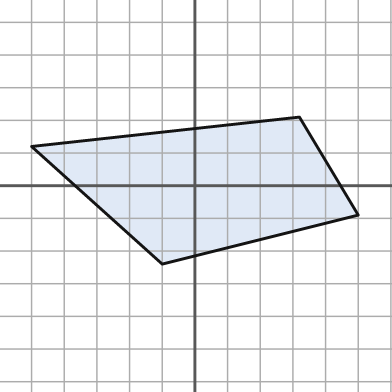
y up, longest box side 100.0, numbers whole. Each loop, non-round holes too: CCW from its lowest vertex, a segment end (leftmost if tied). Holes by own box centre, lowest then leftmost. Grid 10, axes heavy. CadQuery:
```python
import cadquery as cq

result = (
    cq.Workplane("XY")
    .moveTo(-10.0, -24.0)
    .lineTo(50.0, -9.0)
    .lineTo(32.0, 21.0)
    .lineTo(-50.0, 12.0)
    .close()
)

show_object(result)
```